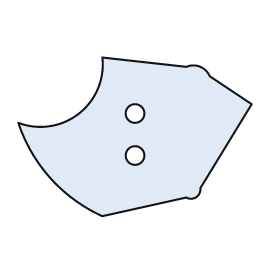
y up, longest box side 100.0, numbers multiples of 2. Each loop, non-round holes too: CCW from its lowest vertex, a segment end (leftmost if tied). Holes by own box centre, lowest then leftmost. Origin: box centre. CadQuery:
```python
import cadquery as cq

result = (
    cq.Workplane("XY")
    .moveTo(-14.0, -34.0)
    .lineTo(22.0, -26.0)
    .threePointArc((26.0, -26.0), (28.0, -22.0))
    .lineTo(50.0, 14.0)
    .lineTo(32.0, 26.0)
    .threePointArc((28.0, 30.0), (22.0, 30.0))
    .lineTo(-14.0, 34.0)
    .threePointArc((-24.0, 10.0), (-50.0, 6.0))
    .threePointArc((-36.0, -18.0), (-14.0, -34.0))
    .close()
    .moveTo(0.0, -8.0)
    .circle(4.0)
    .moveTo(0.0, 10.0)
    .circle(4.0)
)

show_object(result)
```